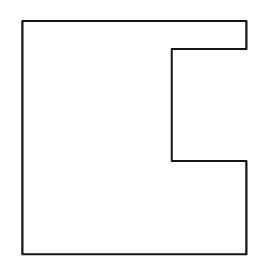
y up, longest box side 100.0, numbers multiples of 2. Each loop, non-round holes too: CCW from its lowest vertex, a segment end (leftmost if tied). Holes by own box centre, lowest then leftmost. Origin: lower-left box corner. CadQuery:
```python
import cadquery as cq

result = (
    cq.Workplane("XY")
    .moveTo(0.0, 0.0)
    .lineTo(96.0, 0.0)
    .lineTo(96.0, 40.0)
    .lineTo(64.0, 40.0)
    .lineTo(64.0, 88.0)
    .lineTo(96.0, 88.0)
    .lineTo(96.0, 100.0)
    .lineTo(0.0, 100.0)
    .close()
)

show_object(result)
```